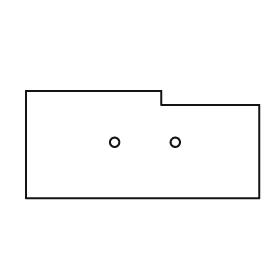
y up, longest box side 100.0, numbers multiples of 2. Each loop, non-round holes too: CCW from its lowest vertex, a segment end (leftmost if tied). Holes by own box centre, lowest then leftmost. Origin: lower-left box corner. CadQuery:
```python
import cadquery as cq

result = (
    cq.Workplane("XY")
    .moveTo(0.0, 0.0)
    .lineTo(100.0, 0.0)
    .lineTo(100.0, 40.0)
    .lineTo(58.0, 40.0)
    .lineTo(58.0, 46.0)
    .lineTo(0.0, 46.0)
    .close()
    .moveTo(38.0, 24.0)
    .circle(2.0)
    .moveTo(64.0, 24.0)
    .circle(2.0)
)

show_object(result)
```